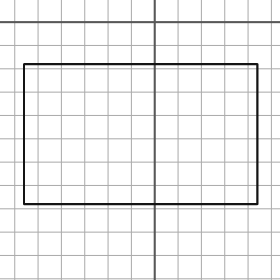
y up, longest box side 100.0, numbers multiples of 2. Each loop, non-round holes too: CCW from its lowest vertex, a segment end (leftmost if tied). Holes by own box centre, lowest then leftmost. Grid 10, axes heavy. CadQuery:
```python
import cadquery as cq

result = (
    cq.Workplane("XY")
    .moveTo(-56.0, -78.0)
    .lineTo(44.0, -78.0)
    .lineTo(44.0, -18.0)
    .lineTo(-56.0, -18.0)
    .close()
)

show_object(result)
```